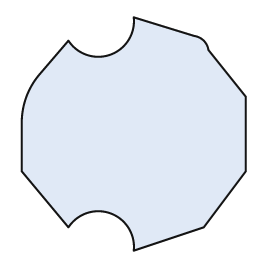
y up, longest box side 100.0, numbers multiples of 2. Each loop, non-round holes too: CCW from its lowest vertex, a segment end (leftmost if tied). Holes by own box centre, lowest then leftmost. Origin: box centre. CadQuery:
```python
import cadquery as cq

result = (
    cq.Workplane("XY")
    .moveTo(0.0, -50.0)
    .lineTo(30.0, -40.0)
    .lineTo(48.0, -16.0)
    .lineTo(48.0, 16.0)
    .lineTo(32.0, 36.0)
    .threePointArc((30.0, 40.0), (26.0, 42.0))
    .lineTo(0.0, 50.0)
    .threePointArc((-10.0, 34.0), (-28.0, 40.0))
    .lineTo(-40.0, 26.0)
    .threePointArc((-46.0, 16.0), (-48.0, 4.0))
    .lineTo(-48.0, -16.0)
    .lineTo(-28.0, -40.0)
    .threePointArc((-10.0, -34.0), (0.0, -50.0))
    .close()
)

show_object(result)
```